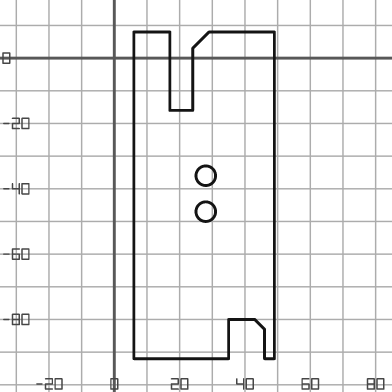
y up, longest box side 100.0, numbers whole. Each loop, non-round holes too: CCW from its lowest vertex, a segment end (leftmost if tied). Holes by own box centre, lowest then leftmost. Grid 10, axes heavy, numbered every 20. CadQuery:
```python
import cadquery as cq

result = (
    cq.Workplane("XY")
    .moveTo(6.0, -92.0)
    .lineTo(35.0, -92.0)
    .lineTo(35.0, -80.0)
    .lineTo(43.0, -80.0)
    .lineTo(46.0, -83.0)
    .lineTo(46.0, -92.0)
    .lineTo(49.0, -92.0)
    .lineTo(49.0, 8.0)
    .lineTo(29.0, 8.0)
    .lineTo(24.0, 3.0)
    .lineTo(24.0, -16.0)
    .lineTo(17.0, -16.0)
    .lineTo(17.0, 8.0)
    .lineTo(6.0, 8.0)
    .close()
    .moveTo(28.0, -47.0)
    .circle(3.0)
    .moveTo(28.0, -36.0)
    .circle(3.0)
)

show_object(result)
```